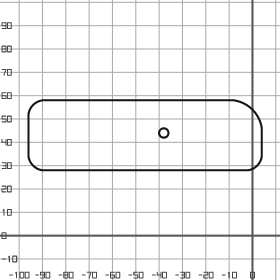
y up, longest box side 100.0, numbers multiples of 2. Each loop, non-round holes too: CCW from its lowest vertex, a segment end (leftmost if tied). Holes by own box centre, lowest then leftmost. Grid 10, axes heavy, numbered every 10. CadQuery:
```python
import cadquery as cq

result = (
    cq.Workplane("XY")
    .moveTo(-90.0, 28.0)
    .lineTo(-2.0, 28.0)
    .threePointArc((2.0, 30.0), (4.0, 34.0))
    .lineTo(4.0, 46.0)
    .threePointArc((0.0, 54.0), (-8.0, 58.0))
    .lineTo(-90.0, 58.0)
    .threePointArc((-94.0, 56.0), (-96.0, 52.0))
    .lineTo(-96.0, 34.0)
    .threePointArc((-94.0, 30.0), (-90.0, 28.0))
    .close()
    .moveTo(-38.0, 44.0)
    .circle(2.0)
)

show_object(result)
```